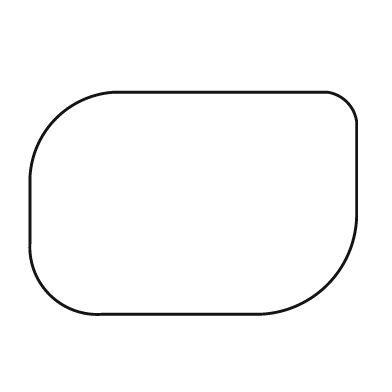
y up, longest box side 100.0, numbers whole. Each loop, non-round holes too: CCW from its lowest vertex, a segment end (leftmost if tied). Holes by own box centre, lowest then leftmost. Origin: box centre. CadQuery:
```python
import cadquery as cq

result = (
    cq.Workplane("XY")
    .moveTo(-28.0, -34.0)
    .lineTo(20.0, -34.0)
    .threePointArc((41.0, -25.0), (50.0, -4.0))
    .lineTo(50.0, 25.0)
    .threePointArc((47.0, 31.0), (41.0, 34.0))
    .lineTo(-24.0, 34.0)
    .threePointArc((-42.0, 26.0), (-50.0, 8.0))
    .lineTo(-50.0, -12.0)
    .threePointArc((-44.0, -28.0), (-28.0, -34.0))
    .close()
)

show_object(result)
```